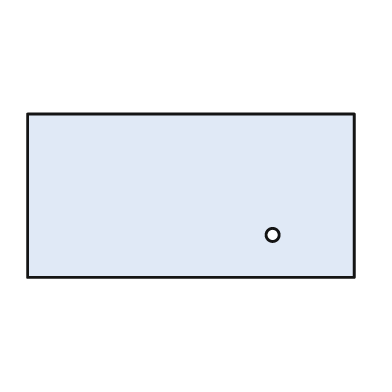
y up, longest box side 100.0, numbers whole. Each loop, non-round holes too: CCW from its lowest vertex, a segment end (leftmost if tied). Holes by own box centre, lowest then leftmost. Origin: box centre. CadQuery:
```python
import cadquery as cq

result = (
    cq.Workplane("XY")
    .moveTo(-50.0, -25.0)
    .lineTo(50.0, -25.0)
    .lineTo(50.0, 25.0)
    .lineTo(-50.0, 25.0)
    .close()
    .moveTo(25.0, -12.0)
    .circle(2.0)
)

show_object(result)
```